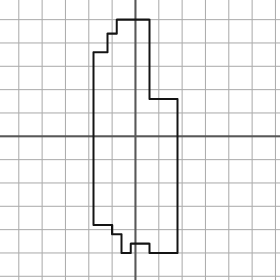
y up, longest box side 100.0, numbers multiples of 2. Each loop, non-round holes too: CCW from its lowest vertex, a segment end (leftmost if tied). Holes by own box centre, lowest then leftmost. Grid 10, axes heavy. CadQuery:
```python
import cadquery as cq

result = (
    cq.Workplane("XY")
    .moveTo(-6.0, -50.0)
    .lineTo(-2.0, -50.0)
    .lineTo(-2.0, -46.0)
    .lineTo(6.0, -46.0)
    .lineTo(6.0, -50.0)
    .lineTo(18.0, -50.0)
    .lineTo(18.0, 16.0)
    .lineTo(6.0, 16.0)
    .lineTo(6.0, 50.0)
    .lineTo(-8.0, 50.0)
    .lineTo(-8.0, 44.0)
    .lineTo(-12.0, 44.0)
    .lineTo(-12.0, 36.0)
    .lineTo(-18.0, 36.0)
    .lineTo(-18.0, -38.0)
    .lineTo(-10.0, -38.0)
    .lineTo(-10.0, -42.0)
    .lineTo(-6.0, -42.0)
    .close()
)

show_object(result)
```